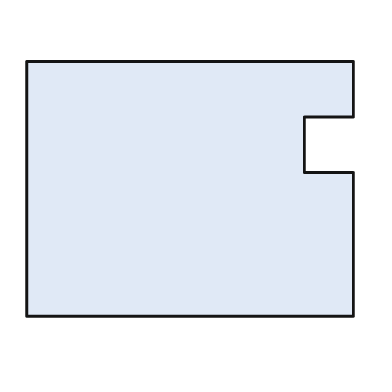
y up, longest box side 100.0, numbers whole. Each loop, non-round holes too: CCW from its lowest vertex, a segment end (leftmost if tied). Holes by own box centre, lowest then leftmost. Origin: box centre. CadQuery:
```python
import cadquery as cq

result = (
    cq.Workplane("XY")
    .moveTo(-50.0, -39.0)
    .lineTo(50.0, -39.0)
    .lineTo(50.0, 5.0)
    .lineTo(35.0, 5.0)
    .lineTo(35.0, 22.0)
    .lineTo(50.0, 22.0)
    .lineTo(50.0, 39.0)
    .lineTo(-50.0, 39.0)
    .close()
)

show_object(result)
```